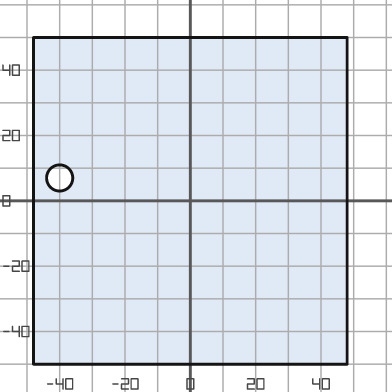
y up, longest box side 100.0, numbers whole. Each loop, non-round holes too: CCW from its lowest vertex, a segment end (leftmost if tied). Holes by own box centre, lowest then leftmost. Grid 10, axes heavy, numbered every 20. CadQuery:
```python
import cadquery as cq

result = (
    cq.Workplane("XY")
    .moveTo(-48.0, -50.0)
    .lineTo(48.0, -50.0)
    .lineTo(48.0, 50.0)
    .lineTo(-48.0, 50.0)
    .close()
    .moveTo(-40.0, 7.0)
    .circle(4.0)
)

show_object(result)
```